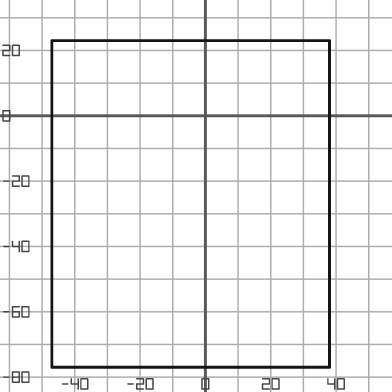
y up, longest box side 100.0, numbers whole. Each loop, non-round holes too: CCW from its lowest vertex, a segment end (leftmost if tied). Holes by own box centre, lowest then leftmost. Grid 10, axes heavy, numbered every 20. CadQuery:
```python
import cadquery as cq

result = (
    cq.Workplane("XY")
    .moveTo(-47.0, -77.0)
    .lineTo(38.0, -77.0)
    .lineTo(38.0, 23.0)
    .lineTo(-47.0, 23.0)
    .close()
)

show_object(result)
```